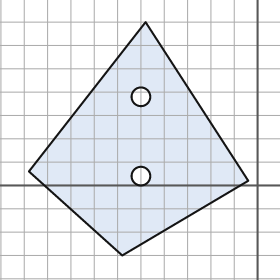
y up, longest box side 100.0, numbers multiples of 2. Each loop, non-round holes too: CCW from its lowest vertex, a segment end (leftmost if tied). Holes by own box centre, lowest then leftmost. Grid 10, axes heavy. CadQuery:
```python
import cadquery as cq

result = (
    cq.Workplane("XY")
    .moveTo(-58.0, -30.0)
    .lineTo(-4.0, 2.0)
    .lineTo(-48.0, 70.0)
    .lineTo(-98.0, 6.0)
    .close()
    .moveTo(-50.0, 4.0)
    .circle(4.0)
    .moveTo(-50.0, 38.0)
    .circle(4.0)
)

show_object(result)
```